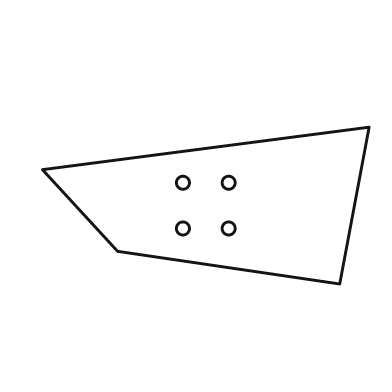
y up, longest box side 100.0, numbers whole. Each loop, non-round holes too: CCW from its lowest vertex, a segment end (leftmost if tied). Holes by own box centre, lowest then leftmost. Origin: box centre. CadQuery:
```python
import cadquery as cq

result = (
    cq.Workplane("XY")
    .moveTo(41.0, -24.0)
    .lineTo(50.0, 24.0)
    .lineTo(-50.0, 11.0)
    .lineTo(-27.0, -14.0)
    .close()
    .moveTo(-7.0, -7.0)
    .circle(2.0)
    .moveTo(7.0, -7.0)
    .circle(2.0)
    .moveTo(-7.0, 7.0)
    .circle(2.0)
    .moveTo(7.0, 7.0)
    .circle(2.0)
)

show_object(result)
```